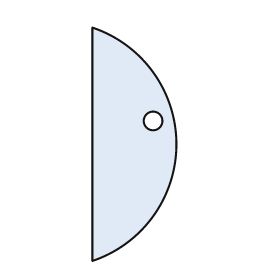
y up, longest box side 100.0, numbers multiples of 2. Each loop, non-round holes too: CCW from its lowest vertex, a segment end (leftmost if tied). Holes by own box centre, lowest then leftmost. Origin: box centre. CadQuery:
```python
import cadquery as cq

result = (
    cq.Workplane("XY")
    .moveTo(-18.0, -50.0)
    .threePointArc((18.0, 0.0), (-18.0, 50.0))
    .close()
    .moveTo(8.0, 10.0)
    .circle(4.0)
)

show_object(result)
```